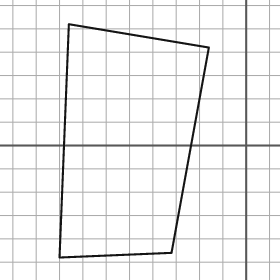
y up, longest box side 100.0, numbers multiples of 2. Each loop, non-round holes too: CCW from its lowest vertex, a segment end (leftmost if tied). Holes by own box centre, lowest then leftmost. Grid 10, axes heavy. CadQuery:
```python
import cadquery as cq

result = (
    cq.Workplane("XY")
    .moveTo(-80.0, -48.0)
    .lineTo(-32.0, -46.0)
    .lineTo(-16.0, 42.0)
    .lineTo(-76.0, 52.0)
    .close()
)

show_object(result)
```